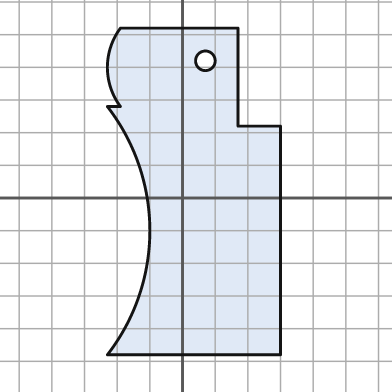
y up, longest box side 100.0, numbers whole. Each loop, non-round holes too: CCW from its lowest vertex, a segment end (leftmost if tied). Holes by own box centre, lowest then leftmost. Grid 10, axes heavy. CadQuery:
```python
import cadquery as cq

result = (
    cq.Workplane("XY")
    .moveTo(-23.0, -48.0)
    .lineTo(30.0, -48.0)
    .lineTo(30.0, 22.0)
    .lineTo(17.0, 22.0)
    .lineTo(17.0, 52.0)
    .lineTo(-19.0, 52.0)
    .threePointArc((-23.0, 40.0), (-19.0, 28.0))
    .lineTo(-23.0, 28.0)
    .threePointArc((-10.0, -10.0), (-23.0, -48.0))
    .close()
    .moveTo(7.0, 42.0)
    .circle(3.0)
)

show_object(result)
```